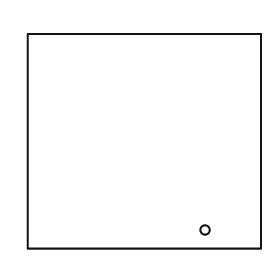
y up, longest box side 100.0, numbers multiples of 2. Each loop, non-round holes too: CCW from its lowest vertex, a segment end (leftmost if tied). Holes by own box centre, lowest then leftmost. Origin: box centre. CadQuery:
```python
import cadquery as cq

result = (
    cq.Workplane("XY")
    .moveTo(-50.0, -46.0)
    .lineTo(50.0, -46.0)
    .lineTo(50.0, 46.0)
    .lineTo(-50.0, 46.0)
    .close()
    .moveTo(26.0, -38.0)
    .circle(2.0)
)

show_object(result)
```